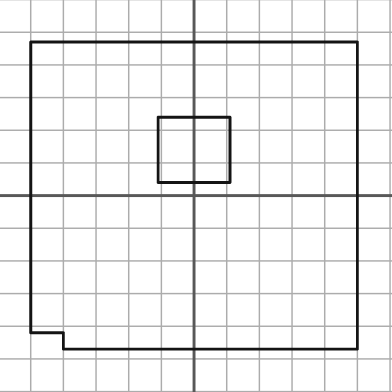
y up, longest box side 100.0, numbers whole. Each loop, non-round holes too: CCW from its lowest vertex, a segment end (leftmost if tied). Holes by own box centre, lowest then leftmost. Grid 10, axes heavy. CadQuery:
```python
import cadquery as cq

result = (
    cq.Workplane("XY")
    .moveTo(-40.0, -47.0)
    .lineTo(50.0, -47.0)
    .lineTo(50.0, 47.0)
    .lineTo(-50.0, 47.0)
    .lineTo(-50.0, -42.0)
    .lineTo(-40.0, -42.0)
    .close()
    .moveTo(-11.0, 4.0)
    .lineTo(11.0, 4.0)
    .lineTo(11.0, 24.0)
    .lineTo(-11.0, 24.0)
    .close()
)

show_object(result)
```